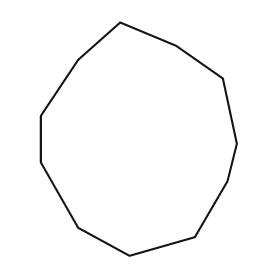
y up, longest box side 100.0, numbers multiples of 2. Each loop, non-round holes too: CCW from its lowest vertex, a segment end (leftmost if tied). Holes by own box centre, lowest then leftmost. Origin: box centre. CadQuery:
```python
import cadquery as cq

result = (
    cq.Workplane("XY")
    .moveTo(-4.0, -50.0)
    .lineTo(24.0, -42.0)
    .lineTo(38.0, -18.0)
    .lineTo(42.0, -2.0)
    .lineTo(36.0, 26.0)
    .lineTo(16.0, 40.0)
    .lineTo(-8.0, 50.0)
    .lineTo(-26.0, 34.0)
    .lineTo(-42.0, 10.0)
    .lineTo(-42.0, -10.0)
    .lineTo(-26.0, -38.0)
    .close()
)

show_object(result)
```